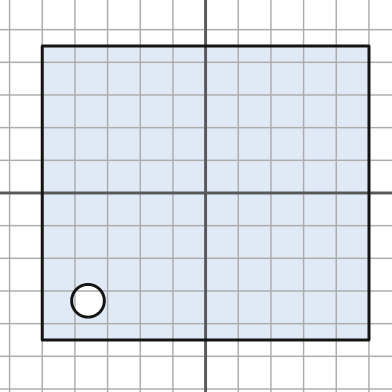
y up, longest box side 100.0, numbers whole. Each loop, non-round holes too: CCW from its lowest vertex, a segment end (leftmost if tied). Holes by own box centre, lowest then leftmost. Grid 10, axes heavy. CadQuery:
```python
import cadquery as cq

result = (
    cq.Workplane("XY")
    .moveTo(-50.0, -45.0)
    .lineTo(50.0, -45.0)
    .lineTo(50.0, 45.0)
    .lineTo(-50.0, 45.0)
    .close()
    .moveTo(-36.0, -33.0)
    .circle(5.0)
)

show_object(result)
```